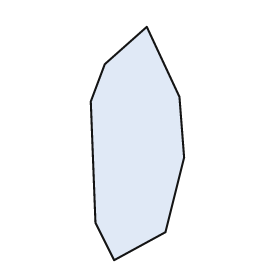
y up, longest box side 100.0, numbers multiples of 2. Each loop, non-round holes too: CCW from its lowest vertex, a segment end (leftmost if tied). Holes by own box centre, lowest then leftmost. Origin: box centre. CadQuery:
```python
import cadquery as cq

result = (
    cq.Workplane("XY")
    .moveTo(-10.0, -50.0)
    .lineTo(12.0, -38.0)
    .lineTo(20.0, -6.0)
    .lineTo(18.0, 20.0)
    .lineTo(4.0, 50.0)
    .lineTo(-14.0, 34.0)
    .lineTo(-20.0, 18.0)
    .lineTo(-18.0, -34.0)
    .close()
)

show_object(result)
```